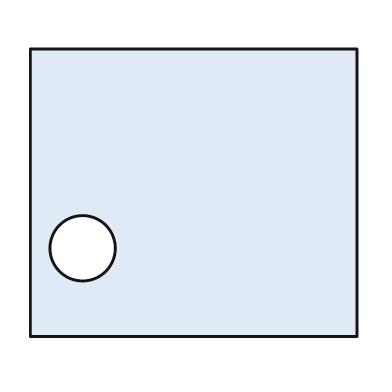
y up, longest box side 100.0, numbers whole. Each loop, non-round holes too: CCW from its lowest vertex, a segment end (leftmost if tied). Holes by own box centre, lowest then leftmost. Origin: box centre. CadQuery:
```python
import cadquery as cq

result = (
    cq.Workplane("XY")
    .moveTo(-50.0, -44.0)
    .lineTo(50.0, -44.0)
    .lineTo(50.0, 44.0)
    .lineTo(-50.0, 44.0)
    .close()
    .moveTo(-34.0, -17.0)
    .circle(10.0)
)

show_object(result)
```